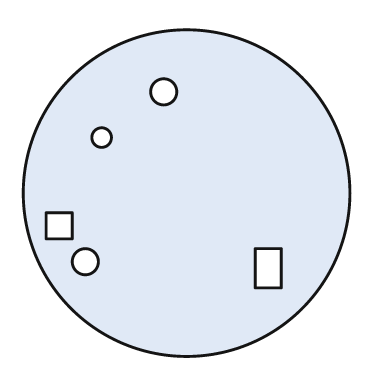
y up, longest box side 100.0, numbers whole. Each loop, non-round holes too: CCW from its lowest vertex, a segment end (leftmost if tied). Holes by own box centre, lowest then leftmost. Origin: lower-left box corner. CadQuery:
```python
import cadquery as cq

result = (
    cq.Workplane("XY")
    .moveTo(50.0, 50.0)
    .circle(50.0)
    .moveTo(71.0, 21.0)
    .lineTo(79.0, 21.0)
    .lineTo(79.0, 33.0)
    .lineTo(71.0, 33.0)
    .close()
    .moveTo(19.0, 29.0)
    .circle(4.0)
    .moveTo(7.0, 36.0)
    .lineTo(15.0, 36.0)
    .lineTo(15.0, 44.0)
    .lineTo(7.0, 44.0)
    .close()
    .moveTo(24.0, 67.0)
    .circle(3.0)
    .moveTo(43.0, 81.0)
    .circle(4.0)
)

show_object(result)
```